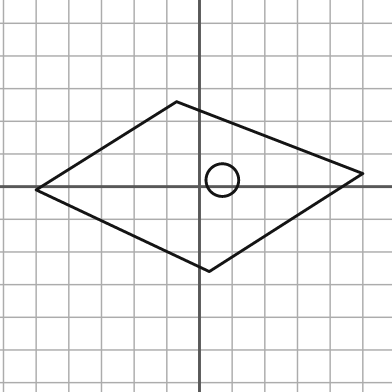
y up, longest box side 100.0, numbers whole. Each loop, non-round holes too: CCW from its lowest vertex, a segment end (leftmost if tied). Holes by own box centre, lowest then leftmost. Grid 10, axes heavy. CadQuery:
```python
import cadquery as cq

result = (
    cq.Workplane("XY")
    .moveTo(3.0, -26.0)
    .lineTo(50.0, 4.0)
    .lineTo(-7.0, 26.0)
    .lineTo(-50.0, -1.0)
    .close()
    .moveTo(7.0, 2.0)
    .circle(5.0)
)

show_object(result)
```